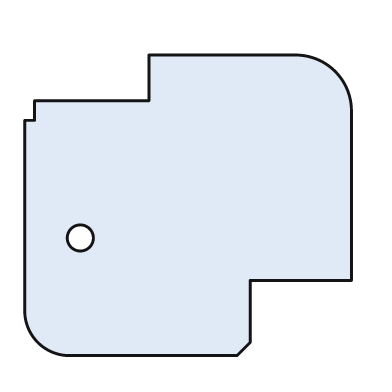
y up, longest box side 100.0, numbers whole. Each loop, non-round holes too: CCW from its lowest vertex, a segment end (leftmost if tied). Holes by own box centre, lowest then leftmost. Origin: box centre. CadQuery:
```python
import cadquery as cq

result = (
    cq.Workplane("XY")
    .moveTo(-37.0, -46.0)
    .lineTo(15.0, -46.0)
    .lineTo(19.0, -42.0)
    .lineTo(19.0, -23.0)
    .lineTo(50.0, -23.0)
    .lineTo(50.0, 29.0)
    .threePointArc((45.0, 41.0), (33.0, 46.0))
    .lineTo(-12.0, 46.0)
    .lineTo(-12.0, 32.0)
    .lineTo(-47.0, 32.0)
    .lineTo(-47.0, 26.0)
    .lineTo(-50.0, 26.0)
    .lineTo(-50.0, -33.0)
    .threePointArc((-46.0, -42.0), (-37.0, -46.0))
    .close()
    .moveTo(-33.0, -10.0)
    .circle(4.0)
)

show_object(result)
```